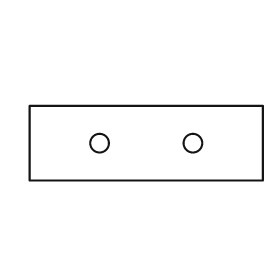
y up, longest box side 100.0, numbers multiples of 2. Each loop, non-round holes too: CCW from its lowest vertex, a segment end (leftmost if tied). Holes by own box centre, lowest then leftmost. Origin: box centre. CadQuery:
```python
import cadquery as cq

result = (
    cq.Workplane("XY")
    .moveTo(-50.0, -16.0)
    .lineTo(50.0, -16.0)
    .lineTo(50.0, 16.0)
    .lineTo(-50.0, 16.0)
    .close()
    .moveTo(-20.0, 0.0)
    .circle(4.0)
    .moveTo(20.0, 0.0)
    .circle(4.0)
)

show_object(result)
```